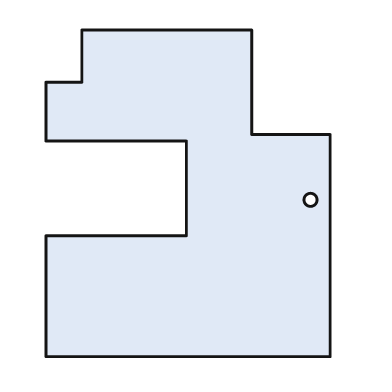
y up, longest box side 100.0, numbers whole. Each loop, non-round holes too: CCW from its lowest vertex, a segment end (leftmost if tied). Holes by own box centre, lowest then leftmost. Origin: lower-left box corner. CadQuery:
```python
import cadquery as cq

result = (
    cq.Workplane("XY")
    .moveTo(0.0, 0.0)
    .lineTo(87.0, 0.0)
    .lineTo(87.0, 68.0)
    .lineTo(63.0, 68.0)
    .lineTo(63.0, 100.0)
    .lineTo(11.0, 100.0)
    .lineTo(11.0, 84.0)
    .lineTo(0.0, 84.0)
    .lineTo(0.0, 66.0)
    .lineTo(43.0, 66.0)
    .lineTo(43.0, 37.0)
    .lineTo(0.0, 37.0)
    .close()
    .moveTo(81.0, 48.0)
    .circle(2.0)
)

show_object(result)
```